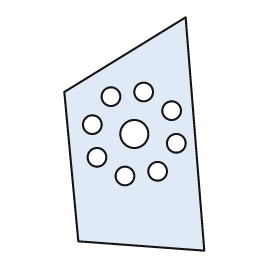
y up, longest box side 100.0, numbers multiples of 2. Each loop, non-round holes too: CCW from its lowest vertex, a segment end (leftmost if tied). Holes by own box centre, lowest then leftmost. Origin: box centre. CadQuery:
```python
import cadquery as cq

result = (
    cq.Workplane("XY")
    .moveTo(30.0, -50.0)
    .lineTo(22.0, 50.0)
    .lineTo(-30.0, 18.0)
    .lineTo(-24.0, -46.0)
    .close()
    .moveTo(-4.0, -18.0)
    .circle(4.0)
    .moveTo(10.0, -16.0)
    .circle(4.0)
    .moveTo(-16.0, -10.0)
    .circle(4.0)
    .moveTo(18.0, -4.0)
    .circle(4.0)
    .moveTo(0.0, 0.0)
    .circle(6.0)
    .moveTo(-18.0, 4.0)
    .circle(4.0)
    .moveTo(16.0, 10.0)
    .circle(4.0)
    .moveTo(-10.0, 16.0)
    .circle(4.0)
    .moveTo(4.0, 18.0)
    .circle(4.0)
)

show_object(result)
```